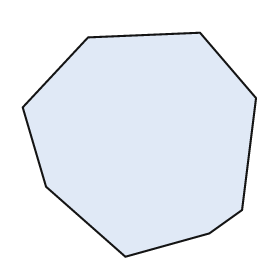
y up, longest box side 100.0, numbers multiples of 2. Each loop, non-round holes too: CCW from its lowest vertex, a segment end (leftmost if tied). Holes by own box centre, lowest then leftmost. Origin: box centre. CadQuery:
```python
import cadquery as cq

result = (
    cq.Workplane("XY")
    .moveTo(-6.0, -48.0)
    .lineTo(30.0, -38.0)
    .lineTo(44.0, -28.0)
    .lineTo(50.0, 20.0)
    .lineTo(26.0, 48.0)
    .lineTo(-22.0, 46.0)
    .lineTo(-50.0, 16.0)
    .lineTo(-40.0, -18.0)
    .close()
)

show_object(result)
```